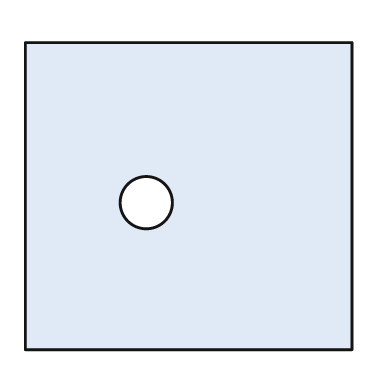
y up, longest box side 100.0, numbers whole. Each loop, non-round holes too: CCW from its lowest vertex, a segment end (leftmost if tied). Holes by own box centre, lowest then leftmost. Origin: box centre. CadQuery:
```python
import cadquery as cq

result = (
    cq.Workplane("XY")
    .moveTo(-50.0, -47.0)
    .lineTo(50.0, -47.0)
    .lineTo(50.0, 47.0)
    .lineTo(-50.0, 47.0)
    .close()
    .moveTo(-13.0, -2.0)
    .circle(8.0)
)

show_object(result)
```